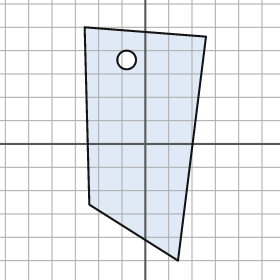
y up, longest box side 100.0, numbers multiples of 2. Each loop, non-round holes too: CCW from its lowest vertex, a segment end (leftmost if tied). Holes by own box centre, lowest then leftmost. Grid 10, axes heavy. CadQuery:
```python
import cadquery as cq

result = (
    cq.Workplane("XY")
    .moveTo(14.0, -50.0)
    .lineTo(26.0, 46.0)
    .lineTo(-26.0, 50.0)
    .lineTo(-24.0, -26.0)
    .close()
    .moveTo(-8.0, 36.0)
    .circle(4.0)
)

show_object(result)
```